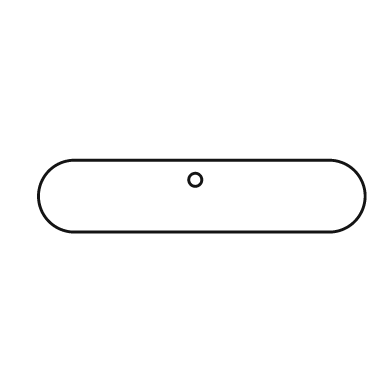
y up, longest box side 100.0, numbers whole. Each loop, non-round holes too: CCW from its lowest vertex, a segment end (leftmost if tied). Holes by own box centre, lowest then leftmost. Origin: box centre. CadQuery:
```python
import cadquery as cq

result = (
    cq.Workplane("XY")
    .moveTo(-39.0, -11.0)
    .lineTo(39.0, -11.0)
    .threePointArc((50.0, 0.0), (39.0, 11.0))
    .lineTo(-39.0, 11.0)
    .threePointArc((-50.0, 0.0), (-39.0, -11.0))
    .close()
    .moveTo(-2.0, 5.0)
    .circle(2.0)
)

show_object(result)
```